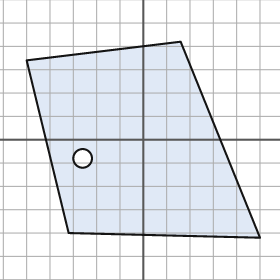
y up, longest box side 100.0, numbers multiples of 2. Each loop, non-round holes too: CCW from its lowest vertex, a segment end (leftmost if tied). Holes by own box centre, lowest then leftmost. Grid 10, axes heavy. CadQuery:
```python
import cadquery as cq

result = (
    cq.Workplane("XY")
    .moveTo(50.0, -42.0)
    .lineTo(16.0, 42.0)
    .lineTo(-50.0, 34.0)
    .lineTo(-32.0, -40.0)
    .close()
    .moveTo(-26.0, -8.0)
    .circle(4.0)
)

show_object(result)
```